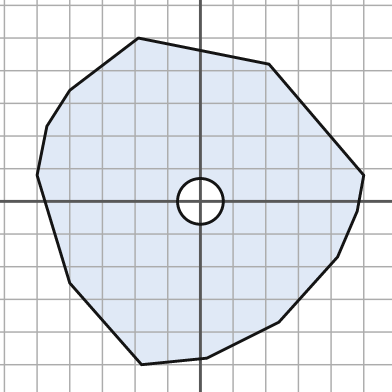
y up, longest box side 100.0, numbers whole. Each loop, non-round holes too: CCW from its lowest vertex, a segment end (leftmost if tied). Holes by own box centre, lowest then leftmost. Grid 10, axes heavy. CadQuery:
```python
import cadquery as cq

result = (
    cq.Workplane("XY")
    .moveTo(-18.0, -50.0)
    .lineTo(2.0, -48.0)
    .lineTo(24.0, -37.0)
    .lineTo(42.0, -17.0)
    .lineTo(48.0, -3.0)
    .lineTo(50.0, 8.0)
    .lineTo(21.0, 42.0)
    .lineTo(-19.0, 50.0)
    .lineTo(-40.0, 34.0)
    .lineTo(-47.0, 23.0)
    .lineTo(-50.0, 8.0)
    .lineTo(-40.0, -25.0)
    .close()
    .moveTo(0.0, 0.0)
    .circle(7.0)
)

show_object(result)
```